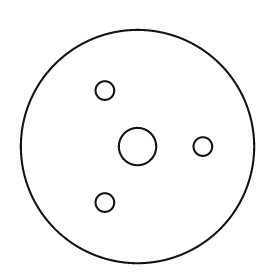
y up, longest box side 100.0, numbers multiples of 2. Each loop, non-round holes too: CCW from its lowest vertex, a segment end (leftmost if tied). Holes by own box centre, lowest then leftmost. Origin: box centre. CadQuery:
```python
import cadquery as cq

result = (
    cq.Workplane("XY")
    .moveTo(0.0, 0.0)
    .circle(50.0)
    .moveTo(-14.0, -24.0)
    .circle(4.0)
    .moveTo(0.0, 0.0)
    .circle(8.0)
    .moveTo(28.0, 0.0)
    .circle(4.0)
    .moveTo(-14.0, 24.0)
    .circle(4.0)
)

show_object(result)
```